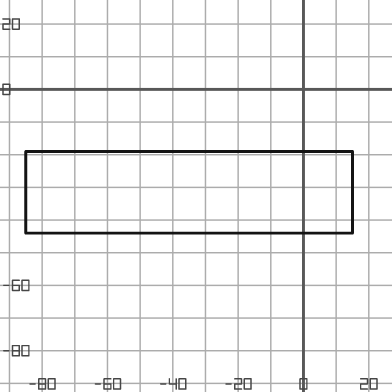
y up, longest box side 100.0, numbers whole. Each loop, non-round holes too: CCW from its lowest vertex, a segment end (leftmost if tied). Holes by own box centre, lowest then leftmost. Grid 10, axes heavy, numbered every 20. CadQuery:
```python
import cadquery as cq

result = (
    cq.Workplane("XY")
    .moveTo(-85.0, -44.0)
    .lineTo(15.0, -44.0)
    .lineTo(15.0, -19.0)
    .lineTo(-85.0, -19.0)
    .close()
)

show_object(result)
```